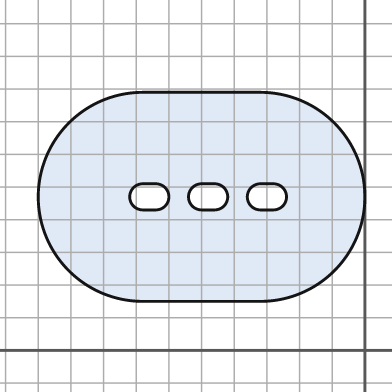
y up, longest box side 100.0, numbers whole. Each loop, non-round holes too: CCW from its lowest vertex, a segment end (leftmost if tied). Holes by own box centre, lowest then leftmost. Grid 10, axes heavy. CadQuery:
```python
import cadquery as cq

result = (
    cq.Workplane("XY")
    .moveTo(-68.0, 15.0)
    .lineTo(-32.0, 15.0)
    .threePointArc((0.0, 47.0), (-32.0, 79.0))
    .lineTo(-68.0, 79.0)
    .threePointArc((-100.0, 47.0), (-68.0, 15.0))
    .close()
    .moveTo(-68.0, 43.0)
    .lineTo(-64.0, 43.0)
    .threePointArc((-60.0, 47.0), (-64.0, 51.0))
    .lineTo(-68.0, 51.0)
    .threePointArc((-72.0, 47.0), (-68.0, 43.0))
    .close()
    .moveTo(-50.0, 43.0)
    .lineTo(-46.0, 43.0)
    .threePointArc((-42.0, 47.0), (-46.0, 51.0))
    .lineTo(-50.0, 51.0)
    .threePointArc((-54.0, 47.0), (-50.0, 43.0))
    .close()
    .moveTo(-32.0, 43.0)
    .lineTo(-28.0, 43.0)
    .threePointArc((-24.0, 47.0), (-28.0, 51.0))
    .lineTo(-32.0, 51.0)
    .threePointArc((-36.0, 47.0), (-32.0, 43.0))
    .close()
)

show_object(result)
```